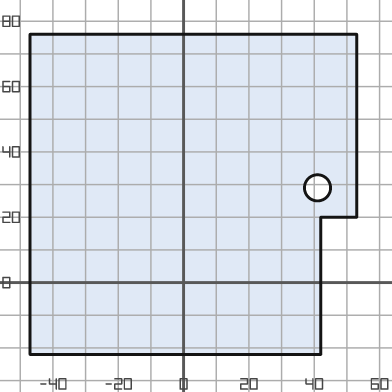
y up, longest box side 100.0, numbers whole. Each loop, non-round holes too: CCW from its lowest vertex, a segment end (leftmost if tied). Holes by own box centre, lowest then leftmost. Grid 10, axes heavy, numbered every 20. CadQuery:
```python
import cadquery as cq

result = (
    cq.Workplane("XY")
    .moveTo(-47.0, -22.0)
    .lineTo(42.0, -22.0)
    .lineTo(42.0, 20.0)
    .lineTo(53.0, 20.0)
    .lineTo(53.0, 76.0)
    .lineTo(-47.0, 76.0)
    .close()
    .moveTo(41.0, 29.0)
    .circle(4.0)
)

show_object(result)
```